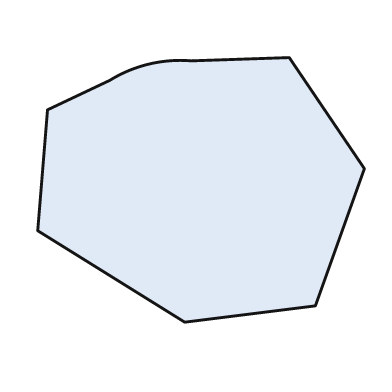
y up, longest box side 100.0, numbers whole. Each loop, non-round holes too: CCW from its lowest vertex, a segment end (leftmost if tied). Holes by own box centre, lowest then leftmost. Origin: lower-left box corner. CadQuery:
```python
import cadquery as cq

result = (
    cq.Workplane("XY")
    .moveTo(45.0, 0.0)
    .lineTo(85.0, 5.0)
    .lineTo(100.0, 47.0)
    .lineTo(77.0, 81.0)
    .lineTo(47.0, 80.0)
    .threePointArc((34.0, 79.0), (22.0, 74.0))
    .lineTo(3.0, 65.0)
    .lineTo(0.0, 28.0)
    .close()
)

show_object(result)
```